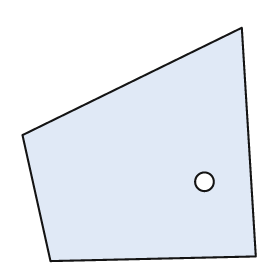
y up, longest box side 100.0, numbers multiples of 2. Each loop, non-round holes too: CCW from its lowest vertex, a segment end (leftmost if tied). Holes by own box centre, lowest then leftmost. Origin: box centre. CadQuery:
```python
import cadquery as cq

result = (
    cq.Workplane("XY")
    .moveTo(-38.0, -50.0)
    .lineTo(50.0, -48.0)
    .lineTo(44.0, 50.0)
    .lineTo(-50.0, 4.0)
    .close()
    .moveTo(28.0, -16.0)
    .circle(4.0)
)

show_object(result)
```